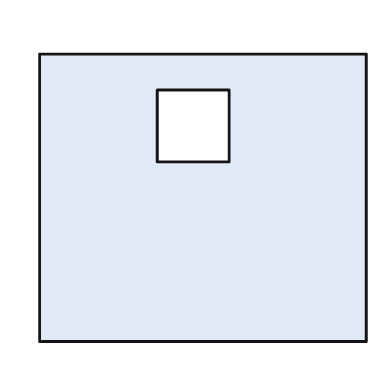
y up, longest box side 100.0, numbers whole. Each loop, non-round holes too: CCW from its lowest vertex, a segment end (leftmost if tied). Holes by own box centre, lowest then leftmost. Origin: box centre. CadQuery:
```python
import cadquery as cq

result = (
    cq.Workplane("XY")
    .moveTo(-50.0, -44.0)
    .lineTo(50.0, -44.0)
    .lineTo(50.0, 44.0)
    .lineTo(-50.0, 44.0)
    .close()
    .moveTo(-14.0, 11.0)
    .lineTo(8.0, 11.0)
    .lineTo(8.0, 33.0)
    .lineTo(-14.0, 33.0)
    .close()
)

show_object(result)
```